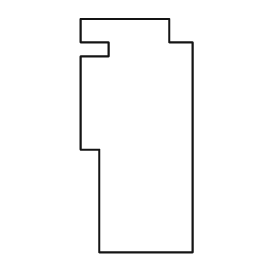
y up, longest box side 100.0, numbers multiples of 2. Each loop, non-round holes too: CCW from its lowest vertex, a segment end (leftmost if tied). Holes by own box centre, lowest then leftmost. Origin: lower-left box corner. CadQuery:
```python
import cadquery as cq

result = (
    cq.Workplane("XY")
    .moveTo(8.0, 0.0)
    .lineTo(48.0, 0.0)
    .lineTo(48.0, 90.0)
    .lineTo(38.0, 90.0)
    .lineTo(38.0, 100.0)
    .lineTo(0.0, 100.0)
    .lineTo(0.0, 90.0)
    .lineTo(12.0, 90.0)
    .lineTo(12.0, 84.0)
    .lineTo(0.0, 84.0)
    .lineTo(0.0, 44.0)
    .lineTo(8.0, 44.0)
    .close()
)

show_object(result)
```